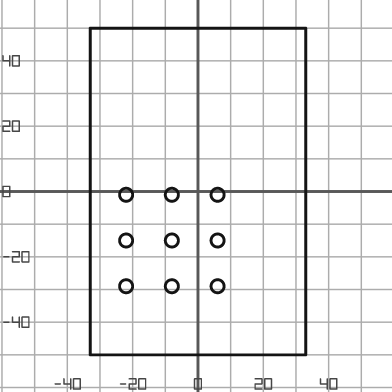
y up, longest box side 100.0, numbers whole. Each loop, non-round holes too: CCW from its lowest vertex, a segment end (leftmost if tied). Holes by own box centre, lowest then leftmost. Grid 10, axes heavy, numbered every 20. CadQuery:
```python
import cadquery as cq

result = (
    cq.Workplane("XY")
    .moveTo(-33.0, -50.0)
    .lineTo(33.0, -50.0)
    .lineTo(33.0, 50.0)
    .lineTo(-33.0, 50.0)
    .close()
    .moveTo(-22.0, -29.0)
    .circle(2.0)
    .moveTo(-8.0, -29.0)
    .circle(2.0)
    .moveTo(6.0, -29.0)
    .circle(2.0)
    .moveTo(-22.0, -15.0)
    .circle(2.0)
    .moveTo(-8.0, -15.0)
    .circle(2.0)
    .moveTo(6.0, -15.0)
    .circle(2.0)
    .moveTo(-22.0, -1.0)
    .circle(2.0)
    .moveTo(-8.0, -1.0)
    .circle(2.0)
    .moveTo(6.0, -1.0)
    .circle(2.0)
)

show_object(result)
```